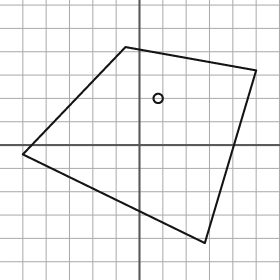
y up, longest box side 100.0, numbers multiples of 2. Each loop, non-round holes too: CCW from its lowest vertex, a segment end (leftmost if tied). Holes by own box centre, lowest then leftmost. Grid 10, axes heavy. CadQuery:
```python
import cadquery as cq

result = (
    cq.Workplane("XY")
    .moveTo(28.0, -42.0)
    .lineTo(50.0, 32.0)
    .lineTo(-6.0, 42.0)
    .lineTo(-50.0, -4.0)
    .close()
    .moveTo(8.0, 20.0)
    .circle(2.0)
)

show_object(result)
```